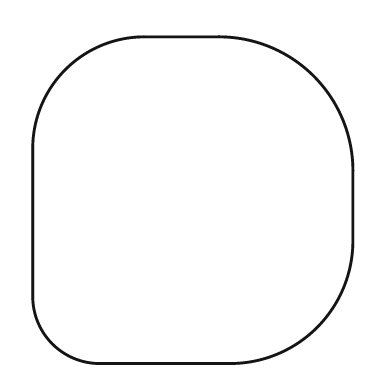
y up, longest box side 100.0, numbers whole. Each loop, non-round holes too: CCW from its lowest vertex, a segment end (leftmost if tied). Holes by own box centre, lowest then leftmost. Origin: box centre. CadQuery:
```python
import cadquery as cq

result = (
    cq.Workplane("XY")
    .moveTo(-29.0, -50.0)
    .lineTo(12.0, -50.0)
    .threePointArc((38.0, -39.0), (49.0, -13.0))
    .lineTo(49.0, 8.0)
    .threePointArc((37.0, 38.0), (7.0, 50.0))
    .lineTo(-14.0, 50.0)
    .threePointArc((-39.0, 40.0), (-49.0, 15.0))
    .lineTo(-49.0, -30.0)
    .threePointArc((-43.0, -44.0), (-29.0, -50.0))
    .close()
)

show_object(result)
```